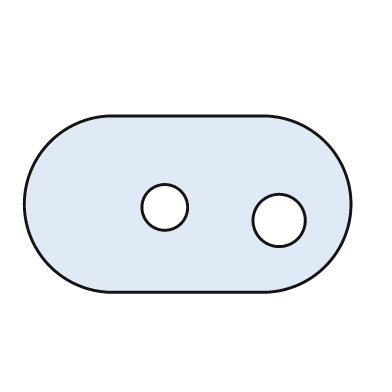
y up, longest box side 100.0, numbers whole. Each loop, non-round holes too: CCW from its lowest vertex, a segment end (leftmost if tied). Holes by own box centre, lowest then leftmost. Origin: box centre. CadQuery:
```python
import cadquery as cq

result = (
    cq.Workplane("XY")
    .moveTo(-23.0, -27.0)
    .lineTo(23.0, -27.0)
    .threePointArc((50.0, 0.0), (23.0, 27.0))
    .lineTo(-23.0, 27.0)
    .threePointArc((-50.0, 0.0), (-23.0, -27.0))
    .close()
    .moveTo(28.0, -5.0)
    .circle(8.0)
    .moveTo(-7.0, -1.0)
    .circle(7.0)
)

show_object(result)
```